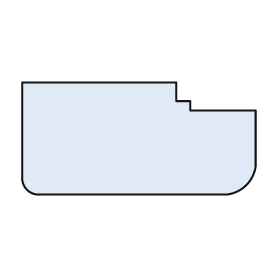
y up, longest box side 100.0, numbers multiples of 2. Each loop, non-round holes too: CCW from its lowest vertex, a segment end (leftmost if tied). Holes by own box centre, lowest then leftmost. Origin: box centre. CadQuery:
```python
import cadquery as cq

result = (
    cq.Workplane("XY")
    .moveTo(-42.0, -24.0)
    .lineTo(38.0, -24.0)
    .threePointArc((46.0, -20.0), (50.0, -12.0))
    .lineTo(50.0, 12.0)
    .lineTo(22.0, 12.0)
    .lineTo(22.0, 16.0)
    .lineTo(16.0, 16.0)
    .lineTo(16.0, 24.0)
    .lineTo(-50.0, 24.0)
    .lineTo(-50.0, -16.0)
    .threePointArc((-48.0, -22.0), (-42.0, -24.0))
    .close()
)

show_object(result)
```